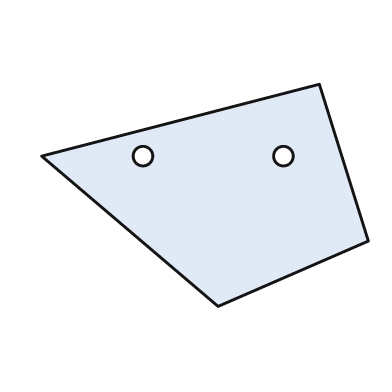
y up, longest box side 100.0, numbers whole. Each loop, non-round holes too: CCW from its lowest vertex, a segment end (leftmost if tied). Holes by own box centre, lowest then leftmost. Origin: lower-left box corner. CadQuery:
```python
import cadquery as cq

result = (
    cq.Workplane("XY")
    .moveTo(54.0, 0.0)
    .lineTo(100.0, 20.0)
    .lineTo(85.0, 68.0)
    .lineTo(0.0, 46.0)
    .close()
    .moveTo(31.0, 46.0)
    .circle(3.0)
    .moveTo(74.0, 46.0)
    .circle(3.0)
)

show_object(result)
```